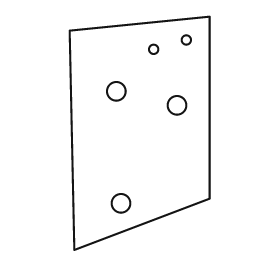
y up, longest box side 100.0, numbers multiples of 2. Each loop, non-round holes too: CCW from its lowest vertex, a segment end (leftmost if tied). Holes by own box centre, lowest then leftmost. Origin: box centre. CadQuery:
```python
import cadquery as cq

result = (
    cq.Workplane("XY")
    .moveTo(-28.0, -50.0)
    .lineTo(30.0, -28.0)
    .lineTo(30.0, 50.0)
    .lineTo(-30.0, 44.0)
    .close()
    .moveTo(-8.0, -30.0)
    .circle(4.0)
    .moveTo(16.0, 12.0)
    .circle(4.0)
    .moveTo(-10.0, 18.0)
    .circle(4.0)
    .moveTo(6.0, 36.0)
    .circle(2.0)
    .moveTo(20.0, 40.0)
    .circle(2.0)
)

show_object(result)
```